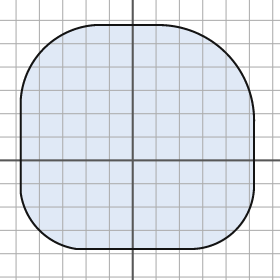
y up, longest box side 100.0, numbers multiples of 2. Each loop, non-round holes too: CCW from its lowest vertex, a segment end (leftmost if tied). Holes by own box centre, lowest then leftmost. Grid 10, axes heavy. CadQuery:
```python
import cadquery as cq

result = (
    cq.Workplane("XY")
    .moveTo(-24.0, -38.0)
    .lineTo(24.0, -38.0)
    .threePointArc((44.0, -30.0), (52.0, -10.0))
    .lineTo(52.0, 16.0)
    .threePointArc((40.0, 46.0), (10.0, 58.0))
    .lineTo(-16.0, 58.0)
    .threePointArc((-38.0, 48.0), (-48.0, 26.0))
    .lineTo(-48.0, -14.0)
    .threePointArc((-40.0, -30.0), (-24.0, -38.0))
    .close()
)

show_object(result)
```